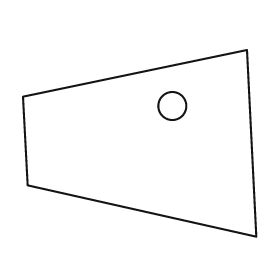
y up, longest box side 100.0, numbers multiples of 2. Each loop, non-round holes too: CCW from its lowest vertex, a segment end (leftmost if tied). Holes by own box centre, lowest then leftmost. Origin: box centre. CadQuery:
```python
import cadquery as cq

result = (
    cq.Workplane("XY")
    .moveTo(50.0, -40.0)
    .lineTo(46.0, 40.0)
    .lineTo(-50.0, 20.0)
    .lineTo(-48.0, -18.0)
    .close()
    .moveTo(14.0, 16.0)
    .circle(6.0)
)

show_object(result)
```